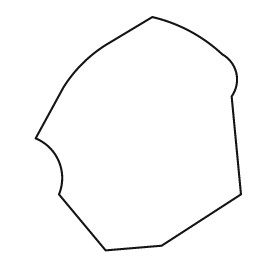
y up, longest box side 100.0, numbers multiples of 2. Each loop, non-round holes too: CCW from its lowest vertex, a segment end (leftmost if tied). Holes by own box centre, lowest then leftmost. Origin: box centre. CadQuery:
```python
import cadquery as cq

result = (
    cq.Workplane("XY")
    .moveTo(-14.0, -50.0)
    .lineTo(10.0, -48.0)
    .lineTo(44.0, -26.0)
    .lineTo(40.0, 16.0)
    .threePointArc((42.0, 26.0), (36.0, 34.0))
    .threePointArc((22.0, 44.0), (6.0, 50.0))
    .lineTo(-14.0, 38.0)
    .threePointArc((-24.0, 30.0), (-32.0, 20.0))
    .lineTo(-44.0, -2.0)
    .threePointArc((-34.0, -12.0), (-34.0, -26.0))
    .close()
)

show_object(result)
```